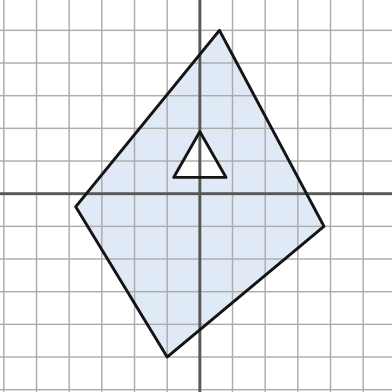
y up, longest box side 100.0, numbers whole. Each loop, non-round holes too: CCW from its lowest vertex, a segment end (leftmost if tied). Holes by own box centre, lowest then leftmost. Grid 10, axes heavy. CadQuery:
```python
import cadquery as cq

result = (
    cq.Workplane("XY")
    .moveTo(-10.0, -50.0)
    .lineTo(38.0, -10.0)
    .lineTo(6.0, 50.0)
    .lineTo(-38.0, -4.0)
    .close()
    .moveTo(-8.0, 5.0)
    .lineTo(8.0, 5.0)
    .lineTo(0.0, 19.0)
    .close()
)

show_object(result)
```